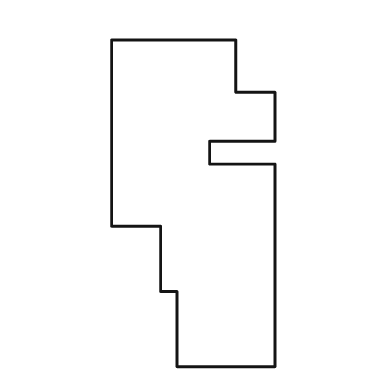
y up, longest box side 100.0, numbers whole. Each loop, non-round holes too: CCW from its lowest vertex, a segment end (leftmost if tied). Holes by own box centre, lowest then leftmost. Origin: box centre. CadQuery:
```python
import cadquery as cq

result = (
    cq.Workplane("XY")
    .moveTo(-5.0, -50.0)
    .lineTo(25.0, -50.0)
    .lineTo(25.0, 12.0)
    .lineTo(5.0, 12.0)
    .lineTo(5.0, 19.0)
    .lineTo(25.0, 19.0)
    .lineTo(25.0, 34.0)
    .lineTo(13.0, 34.0)
    .lineTo(13.0, 50.0)
    .lineTo(-25.0, 50.0)
    .lineTo(-25.0, -7.0)
    .lineTo(-10.0, -7.0)
    .lineTo(-10.0, -27.0)
    .lineTo(-5.0, -27.0)
    .close()
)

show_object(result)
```